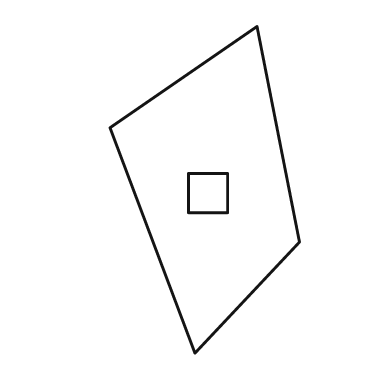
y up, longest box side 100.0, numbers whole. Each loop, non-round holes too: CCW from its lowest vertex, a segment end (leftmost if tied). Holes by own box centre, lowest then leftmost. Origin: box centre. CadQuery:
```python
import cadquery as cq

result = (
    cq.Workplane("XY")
    .moveTo(-3.0, -50.0)
    .lineTo(29.0, -16.0)
    .lineTo(16.0, 50.0)
    .lineTo(-29.0, 19.0)
    .close()
    .moveTo(-5.0, -7.0)
    .lineTo(7.0, -7.0)
    .lineTo(7.0, 5.0)
    .lineTo(-5.0, 5.0)
    .close()
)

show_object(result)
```